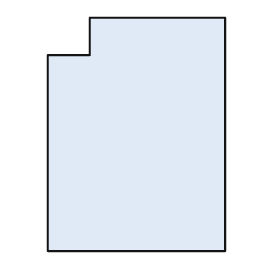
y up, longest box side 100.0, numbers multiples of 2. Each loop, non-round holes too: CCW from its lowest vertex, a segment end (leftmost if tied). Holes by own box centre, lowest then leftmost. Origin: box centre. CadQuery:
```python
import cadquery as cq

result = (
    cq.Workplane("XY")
    .moveTo(-38.0, -50.0)
    .lineTo(38.0, -50.0)
    .lineTo(38.0, 50.0)
    .lineTo(-20.0, 50.0)
    .lineTo(-20.0, 34.0)
    .lineTo(-38.0, 34.0)
    .close()
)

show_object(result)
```